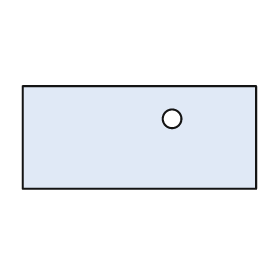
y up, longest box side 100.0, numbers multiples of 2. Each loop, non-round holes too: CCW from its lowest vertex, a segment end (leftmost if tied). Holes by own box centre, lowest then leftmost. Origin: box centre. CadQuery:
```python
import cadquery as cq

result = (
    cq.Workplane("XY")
    .moveTo(-50.0, -22.0)
    .lineTo(50.0, -22.0)
    .lineTo(50.0, 22.0)
    .lineTo(-50.0, 22.0)
    .close()
    .moveTo(14.0, 8.0)
    .circle(4.0)
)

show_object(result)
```